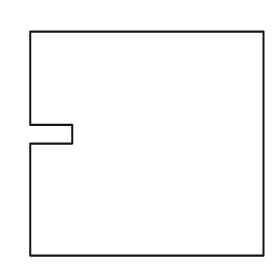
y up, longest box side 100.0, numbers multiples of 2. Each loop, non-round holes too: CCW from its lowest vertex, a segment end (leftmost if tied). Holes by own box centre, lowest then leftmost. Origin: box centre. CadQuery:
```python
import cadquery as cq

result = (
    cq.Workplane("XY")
    .moveTo(-50.0, -48.0)
    .lineTo(50.0, -48.0)
    .lineTo(50.0, 48.0)
    .lineTo(-50.0, 48.0)
    .lineTo(-50.0, 8.0)
    .lineTo(-32.0, 8.0)
    .lineTo(-32.0, 0.0)
    .lineTo(-50.0, 0.0)
    .close()
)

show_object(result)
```